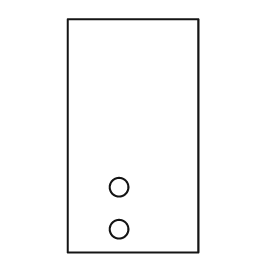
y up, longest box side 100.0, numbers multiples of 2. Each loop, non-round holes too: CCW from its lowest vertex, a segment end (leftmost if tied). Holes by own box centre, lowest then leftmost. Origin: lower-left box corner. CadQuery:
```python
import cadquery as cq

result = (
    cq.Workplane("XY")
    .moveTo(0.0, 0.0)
    .lineTo(56.0, 0.0)
    .lineTo(56.0, 100.0)
    .lineTo(0.0, 100.0)
    .close()
    .moveTo(22.0, 10.0)
    .circle(4.0)
    .moveTo(22.0, 28.0)
    .circle(4.0)
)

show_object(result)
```